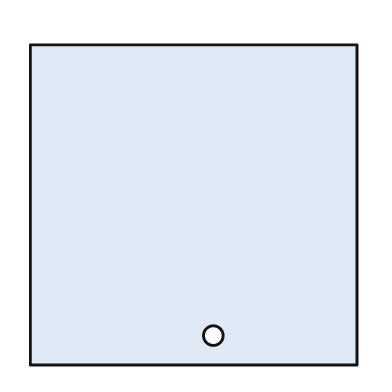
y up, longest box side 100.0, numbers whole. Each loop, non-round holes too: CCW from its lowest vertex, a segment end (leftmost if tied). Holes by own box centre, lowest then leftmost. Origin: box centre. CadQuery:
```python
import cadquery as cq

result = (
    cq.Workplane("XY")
    .moveTo(-50.0, -49.0)
    .lineTo(50.0, -49.0)
    .lineTo(50.0, 49.0)
    .lineTo(-50.0, 49.0)
    .close()
    .moveTo(6.0, -40.0)
    .circle(3.0)
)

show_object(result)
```